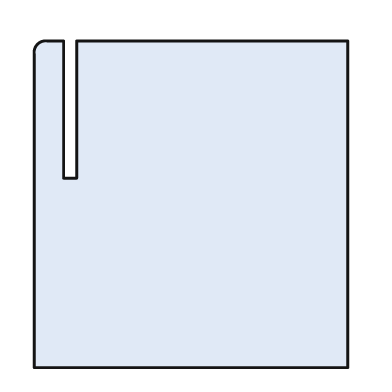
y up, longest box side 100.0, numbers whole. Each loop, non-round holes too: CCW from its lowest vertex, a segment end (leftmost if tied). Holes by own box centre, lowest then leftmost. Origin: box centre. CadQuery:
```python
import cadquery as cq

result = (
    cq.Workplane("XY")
    .moveTo(-48.0, -50.0)
    .lineTo(48.0, -50.0)
    .lineTo(48.0, 50.0)
    .lineTo(-35.0, 50.0)
    .lineTo(-35.0, 8.0)
    .lineTo(-39.0, 8.0)
    .lineTo(-39.0, 50.0)
    .lineTo(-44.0, 50.0)
    .threePointArc((-47.0, 49.0), (-48.0, 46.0))
    .close()
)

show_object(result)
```